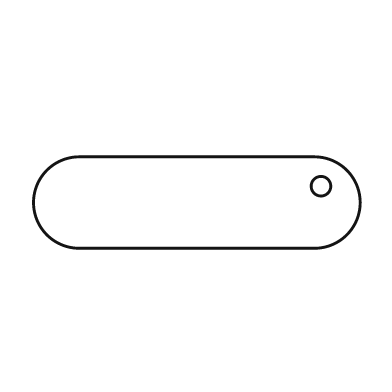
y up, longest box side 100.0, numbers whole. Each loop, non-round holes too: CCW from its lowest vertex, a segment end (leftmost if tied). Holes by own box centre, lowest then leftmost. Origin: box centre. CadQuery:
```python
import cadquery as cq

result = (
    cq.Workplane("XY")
    .moveTo(-36.0, -14.0)
    .lineTo(36.0, -14.0)
    .threePointArc((50.0, 0.0), (36.0, 14.0))
    .lineTo(-36.0, 14.0)
    .threePointArc((-50.0, 0.0), (-36.0, -14.0))
    .close()
    .moveTo(38.0, 5.0)
    .circle(3.0)
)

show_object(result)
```